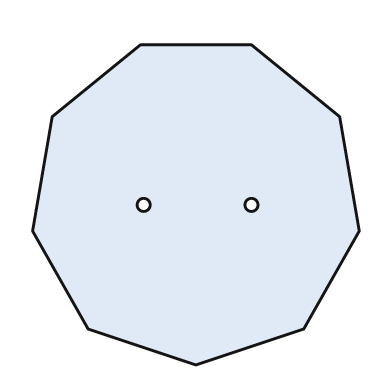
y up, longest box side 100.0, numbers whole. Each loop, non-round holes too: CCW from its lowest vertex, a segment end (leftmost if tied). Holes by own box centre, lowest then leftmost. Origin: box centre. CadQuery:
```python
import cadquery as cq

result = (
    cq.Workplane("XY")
    .moveTo(0.0, -49.0)
    .lineTo(33.0, -38.0)
    .lineTo(50.0, -8.0)
    .lineTo(44.0, 27.0)
    .lineTo(17.0, 49.0)
    .lineTo(-17.0, 49.0)
    .lineTo(-44.0, 27.0)
    .lineTo(-50.0, -8.0)
    .lineTo(-33.0, -38.0)
    .close()
    .moveTo(-16.0, 0.0)
    .circle(2.0)
    .moveTo(17.0, 0.0)
    .circle(2.0)
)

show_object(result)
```